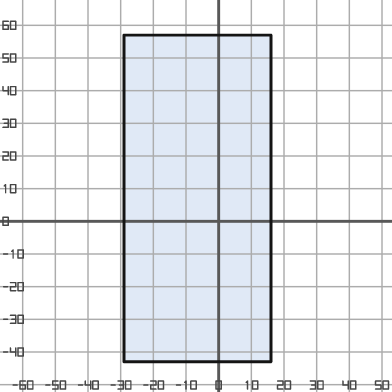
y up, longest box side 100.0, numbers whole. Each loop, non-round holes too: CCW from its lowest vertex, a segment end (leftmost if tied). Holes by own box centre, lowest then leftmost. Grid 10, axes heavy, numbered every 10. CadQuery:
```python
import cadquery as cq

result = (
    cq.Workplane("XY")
    .moveTo(-29.0, -43.0)
    .lineTo(16.0, -43.0)
    .lineTo(16.0, 57.0)
    .lineTo(-29.0, 57.0)
    .close()
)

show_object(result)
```